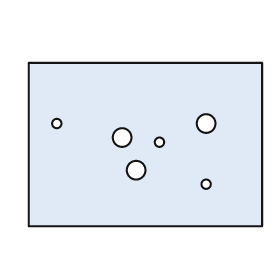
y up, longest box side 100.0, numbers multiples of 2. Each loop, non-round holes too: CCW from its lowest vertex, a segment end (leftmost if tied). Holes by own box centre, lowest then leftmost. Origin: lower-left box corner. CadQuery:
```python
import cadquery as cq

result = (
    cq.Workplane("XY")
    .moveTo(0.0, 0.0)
    .lineTo(100.0, 0.0)
    .lineTo(100.0, 70.0)
    .lineTo(0.0, 70.0)
    .close()
    .moveTo(76.0, 18.0)
    .circle(2.0)
    .moveTo(46.0, 24.0)
    .circle(4.0)
    .moveTo(56.0, 36.0)
    .circle(2.0)
    .moveTo(40.0, 38.0)
    .circle(4.0)
    .moveTo(12.0, 44.0)
    .circle(2.0)
    .moveTo(76.0, 44.0)
    .circle(4.0)
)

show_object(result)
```